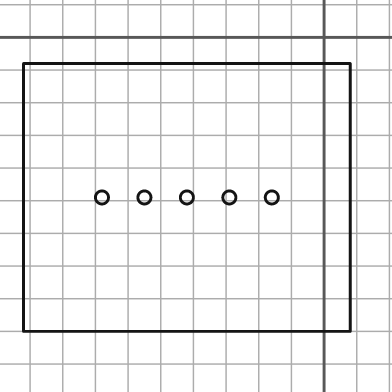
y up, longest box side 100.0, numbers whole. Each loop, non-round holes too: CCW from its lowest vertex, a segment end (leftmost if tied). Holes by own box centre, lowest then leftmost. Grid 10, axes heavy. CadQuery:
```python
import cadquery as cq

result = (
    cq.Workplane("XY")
    .moveTo(-92.0, -90.0)
    .lineTo(8.0, -90.0)
    .lineTo(8.0, -8.0)
    .lineTo(-92.0, -8.0)
    .close()
    .moveTo(-68.0, -49.0)
    .circle(2.0)
    .moveTo(-55.0, -49.0)
    .circle(2.0)
    .moveTo(-42.0, -49.0)
    .circle(2.0)
    .moveTo(-29.0, -49.0)
    .circle(2.0)
    .moveTo(-16.0, -49.0)
    .circle(2.0)
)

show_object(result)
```